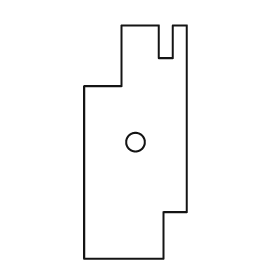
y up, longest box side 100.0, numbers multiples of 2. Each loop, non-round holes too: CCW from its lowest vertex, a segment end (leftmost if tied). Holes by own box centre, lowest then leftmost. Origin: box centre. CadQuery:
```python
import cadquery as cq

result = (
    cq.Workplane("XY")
    .moveTo(-22.0, -50.0)
    .lineTo(12.0, -50.0)
    .lineTo(12.0, -30.0)
    .lineTo(22.0, -30.0)
    .lineTo(22.0, 50.0)
    .lineTo(16.0, 50.0)
    .lineTo(16.0, 36.0)
    .lineTo(10.0, 36.0)
    .lineTo(10.0, 50.0)
    .lineTo(-6.0, 50.0)
    .lineTo(-6.0, 24.0)
    .lineTo(-22.0, 24.0)
    .close()
    .moveTo(0.0, 0.0)
    .circle(4.0)
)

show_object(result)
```